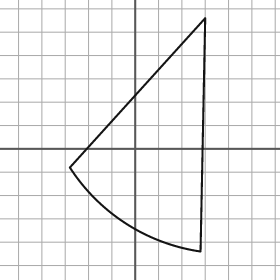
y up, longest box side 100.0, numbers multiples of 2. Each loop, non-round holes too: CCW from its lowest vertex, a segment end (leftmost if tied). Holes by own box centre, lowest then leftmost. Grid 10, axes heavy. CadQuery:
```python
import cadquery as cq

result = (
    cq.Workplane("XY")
    .moveTo(28.0, -44.0)
    .lineTo(30.0, 56.0)
    .lineTo(-28.0, -8.0)
    .threePointArc((-4.0, -32.0), (28.0, -44.0))
    .close()
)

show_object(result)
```